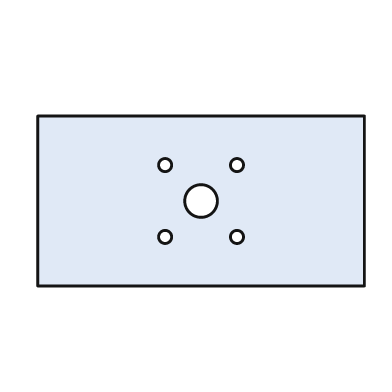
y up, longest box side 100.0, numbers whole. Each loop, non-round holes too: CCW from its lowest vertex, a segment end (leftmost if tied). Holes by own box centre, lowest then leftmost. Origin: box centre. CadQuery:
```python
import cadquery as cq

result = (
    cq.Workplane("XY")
    .moveTo(-50.0, -26.0)
    .lineTo(50.0, -26.0)
    .lineTo(50.0, 26.0)
    .lineTo(-50.0, 26.0)
    .close()
    .moveTo(-11.0, -11.0)
    .circle(2.0)
    .moveTo(11.0, -11.0)
    .circle(2.0)
    .moveTo(0.0, 0.0)
    .circle(5.0)
    .moveTo(-11.0, 11.0)
    .circle(2.0)
    .moveTo(11.0, 11.0)
    .circle(2.0)
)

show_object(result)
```